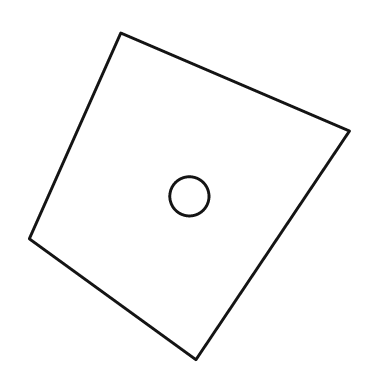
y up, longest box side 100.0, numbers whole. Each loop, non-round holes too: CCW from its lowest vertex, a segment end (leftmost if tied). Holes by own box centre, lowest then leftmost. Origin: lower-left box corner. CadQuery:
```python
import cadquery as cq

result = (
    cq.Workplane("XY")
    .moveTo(51.0, 0.0)
    .lineTo(98.0, 70.0)
    .lineTo(28.0, 100.0)
    .lineTo(0.0, 37.0)
    .close()
    .moveTo(49.0, 50.0)
    .circle(6.0)
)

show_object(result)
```